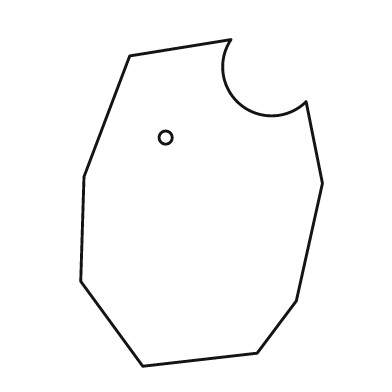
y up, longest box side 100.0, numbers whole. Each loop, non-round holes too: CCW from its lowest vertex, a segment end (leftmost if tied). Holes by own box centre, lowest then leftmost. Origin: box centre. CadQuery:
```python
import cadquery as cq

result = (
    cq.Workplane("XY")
    .moveTo(-18.0, -50.0)
    .lineTo(17.0, -46.0)
    .lineTo(29.0, -30.0)
    .lineTo(37.0, 6.0)
    .lineTo(32.0, 31.0)
    .threePointArc((12.0, 30.0), (9.0, 50.0))
    .lineTo(-22.0, 45.0)
    .lineTo(-36.0, 8.0)
    .lineTo(-37.0, -24.0)
    .close()
    .moveTo(-11.0, 20.0)
    .circle(2.0)
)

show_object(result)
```